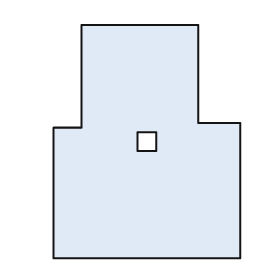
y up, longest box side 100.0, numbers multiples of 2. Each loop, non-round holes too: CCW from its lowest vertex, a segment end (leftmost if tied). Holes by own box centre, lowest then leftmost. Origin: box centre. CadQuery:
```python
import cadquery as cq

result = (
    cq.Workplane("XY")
    .moveTo(-40.0, -50.0)
    .lineTo(40.0, -50.0)
    .lineTo(40.0, 8.0)
    .lineTo(22.0, 8.0)
    .lineTo(22.0, 50.0)
    .lineTo(-28.0, 50.0)
    .lineTo(-28.0, 6.0)
    .lineTo(-40.0, 6.0)
    .close()
    .moveTo(-4.0, -4.0)
    .lineTo(4.0, -4.0)
    .lineTo(4.0, 4.0)
    .lineTo(-4.0, 4.0)
    .close()
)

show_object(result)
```